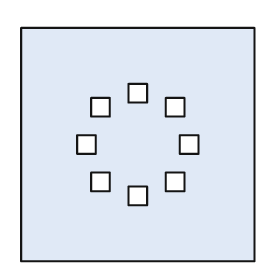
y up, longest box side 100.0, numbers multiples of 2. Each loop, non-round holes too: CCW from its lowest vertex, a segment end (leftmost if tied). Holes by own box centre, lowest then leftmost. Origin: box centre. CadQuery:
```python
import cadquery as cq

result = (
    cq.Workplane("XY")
    .moveTo(-50.0, -50.0)
    .lineTo(50.0, -50.0)
    .lineTo(50.0, 50.0)
    .lineTo(-50.0, 50.0)
    .close()
    .moveTo(-4.0, -26.0)
    .lineTo(4.0, -26.0)
    .lineTo(4.0, -18.0)
    .lineTo(-4.0, -18.0)
    .close()
    .moveTo(-20.0, -20.0)
    .lineTo(-12.0, -20.0)
    .lineTo(-12.0, -12.0)
    .lineTo(-20.0, -12.0)
    .close()
    .moveTo(12.0, -20.0)
    .lineTo(20.0, -20.0)
    .lineTo(20.0, -12.0)
    .lineTo(12.0, -12.0)
    .close()
    .moveTo(-26.0, -4.0)
    .lineTo(-18.0, -4.0)
    .lineTo(-18.0, 4.0)
    .lineTo(-26.0, 4.0)
    .close()
    .moveTo(18.0, -4.0)
    .lineTo(26.0, -4.0)
    .lineTo(26.0, 4.0)
    .lineTo(18.0, 4.0)
    .close()
    .moveTo(-20.0, 12.0)
    .lineTo(-12.0, 12.0)
    .lineTo(-12.0, 20.0)
    .lineTo(-20.0, 20.0)
    .close()
    .moveTo(12.0, 12.0)
    .lineTo(20.0, 12.0)
    .lineTo(20.0, 20.0)
    .lineTo(12.0, 20.0)
    .close()
    .moveTo(-4.0, 18.0)
    .lineTo(4.0, 18.0)
    .lineTo(4.0, 26.0)
    .lineTo(-4.0, 26.0)
    .close()
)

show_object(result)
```